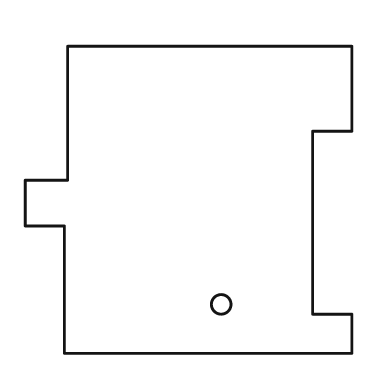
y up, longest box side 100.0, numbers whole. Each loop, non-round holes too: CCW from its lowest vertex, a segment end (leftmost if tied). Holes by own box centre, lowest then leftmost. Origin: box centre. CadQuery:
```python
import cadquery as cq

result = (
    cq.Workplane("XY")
    .moveTo(-38.0, -47.0)
    .lineTo(50.0, -47.0)
    .lineTo(50.0, -35.0)
    .lineTo(38.0, -35.0)
    .lineTo(38.0, 21.0)
    .lineTo(50.0, 21.0)
    .lineTo(50.0, 47.0)
    .lineTo(-37.0, 47.0)
    .lineTo(-37.0, 6.0)
    .lineTo(-50.0, 6.0)
    .lineTo(-50.0, -8.0)
    .lineTo(-38.0, -8.0)
    .close()
    .moveTo(10.0, -32.0)
    .circle(3.0)
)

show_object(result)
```